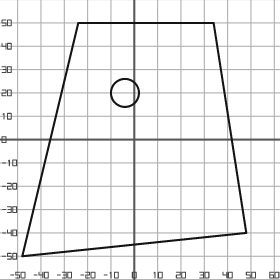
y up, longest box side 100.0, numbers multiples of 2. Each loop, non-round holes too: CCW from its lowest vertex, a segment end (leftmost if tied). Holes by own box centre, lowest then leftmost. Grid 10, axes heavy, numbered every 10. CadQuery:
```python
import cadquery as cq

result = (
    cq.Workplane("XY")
    .moveTo(-48.0, -50.0)
    .lineTo(48.0, -40.0)
    .lineTo(34.0, 50.0)
    .lineTo(-24.0, 50.0)
    .close()
    .moveTo(-4.0, 20.0)
    .circle(6.0)
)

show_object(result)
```